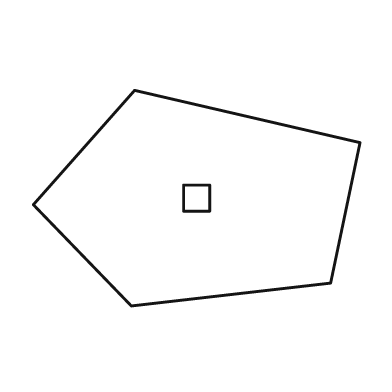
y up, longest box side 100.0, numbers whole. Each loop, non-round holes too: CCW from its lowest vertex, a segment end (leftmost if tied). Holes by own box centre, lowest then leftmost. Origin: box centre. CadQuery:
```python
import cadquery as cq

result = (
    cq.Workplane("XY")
    .moveTo(-20.0, -33.0)
    .lineTo(41.0, -26.0)
    .lineTo(50.0, 17.0)
    .lineTo(-19.0, 33.0)
    .lineTo(-50.0, -2.0)
    .close()
    .moveTo(-4.0, -4.0)
    .lineTo(4.0, -4.0)
    .lineTo(4.0, 4.0)
    .lineTo(-4.0, 4.0)
    .close()
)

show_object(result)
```